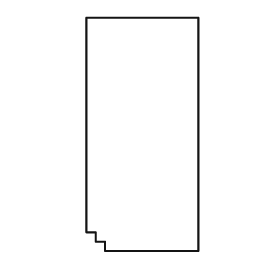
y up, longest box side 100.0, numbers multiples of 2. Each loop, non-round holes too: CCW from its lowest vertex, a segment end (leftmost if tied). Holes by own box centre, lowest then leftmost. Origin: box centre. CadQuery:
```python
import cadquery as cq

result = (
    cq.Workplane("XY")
    .moveTo(-16.0, -50.0)
    .lineTo(24.0, -50.0)
    .lineTo(24.0, 50.0)
    .lineTo(-24.0, 50.0)
    .lineTo(-24.0, -42.0)
    .lineTo(-20.0, -42.0)
    .lineTo(-20.0, -46.0)
    .lineTo(-16.0, -46.0)
    .close()
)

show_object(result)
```